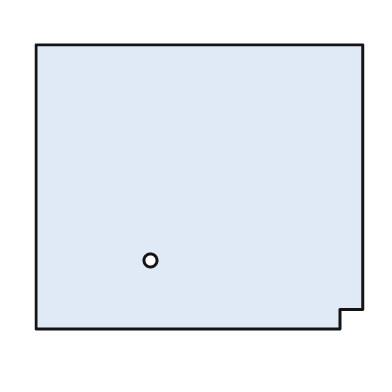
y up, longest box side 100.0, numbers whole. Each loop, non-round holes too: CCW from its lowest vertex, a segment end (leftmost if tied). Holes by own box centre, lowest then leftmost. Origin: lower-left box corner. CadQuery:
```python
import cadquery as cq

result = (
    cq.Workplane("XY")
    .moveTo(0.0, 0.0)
    .lineTo(93.0, 0.0)
    .lineTo(93.0, 6.0)
    .lineTo(100.0, 6.0)
    .lineTo(100.0, 87.0)
    .lineTo(0.0, 87.0)
    .close()
    .moveTo(35.0, 21.0)
    .circle(2.0)
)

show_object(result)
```